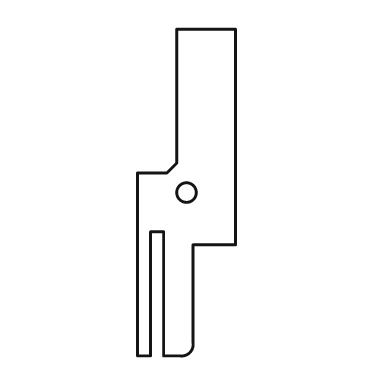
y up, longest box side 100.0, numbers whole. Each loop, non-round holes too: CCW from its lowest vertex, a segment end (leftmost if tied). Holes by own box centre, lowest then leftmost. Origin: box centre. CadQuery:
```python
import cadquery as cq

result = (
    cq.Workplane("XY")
    .moveTo(-15.0, -50.0)
    .lineTo(-11.0, -50.0)
    .lineTo(-11.0, -12.0)
    .lineTo(-7.0, -12.0)
    .lineTo(-7.0, -50.0)
    .lineTo(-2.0, -50.0)
    .threePointArc((1.0, -49.0), (2.0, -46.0))
    .lineTo(2.0, -16.0)
    .lineTo(15.0, -16.0)
    .lineTo(15.0, 50.0)
    .lineTo(-3.0, 50.0)
    .lineTo(-3.0, 9.0)
    .lineTo(-6.0, 6.0)
    .lineTo(-15.0, 6.0)
    .close()
    .moveTo(0.0, 0.0)
    .circle(3.0)
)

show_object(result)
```